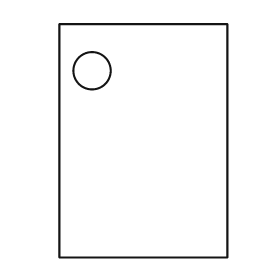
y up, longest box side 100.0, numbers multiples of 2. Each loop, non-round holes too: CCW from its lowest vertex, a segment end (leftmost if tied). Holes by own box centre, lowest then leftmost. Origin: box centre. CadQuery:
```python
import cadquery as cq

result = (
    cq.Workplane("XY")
    .moveTo(-36.0, -50.0)
    .lineTo(36.0, -50.0)
    .lineTo(36.0, 50.0)
    .lineTo(-36.0, 50.0)
    .close()
    .moveTo(-22.0, 30.0)
    .circle(8.0)
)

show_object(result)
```